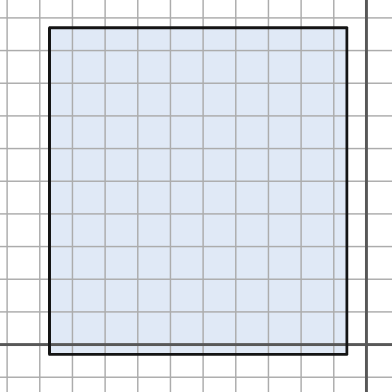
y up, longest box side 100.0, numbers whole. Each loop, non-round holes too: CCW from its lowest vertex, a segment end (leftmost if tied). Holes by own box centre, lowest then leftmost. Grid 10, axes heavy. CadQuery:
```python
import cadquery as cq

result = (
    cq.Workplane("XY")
    .moveTo(-97.0, -3.0)
    .lineTo(-6.0, -3.0)
    .lineTo(-6.0, 97.0)
    .lineTo(-97.0, 97.0)
    .close()
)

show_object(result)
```